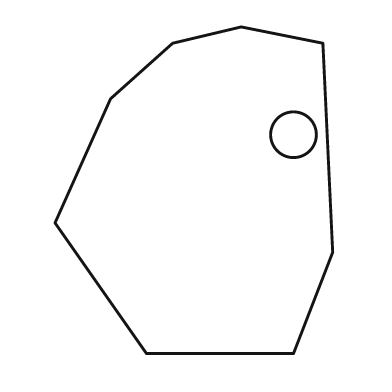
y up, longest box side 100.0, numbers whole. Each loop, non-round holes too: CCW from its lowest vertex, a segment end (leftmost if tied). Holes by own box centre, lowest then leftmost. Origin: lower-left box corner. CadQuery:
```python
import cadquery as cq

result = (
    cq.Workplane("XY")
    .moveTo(28.0, 0.0)
    .lineTo(73.0, 0.0)
    .lineTo(85.0, 31.0)
    .lineTo(82.0, 95.0)
    .lineTo(57.0, 100.0)
    .lineTo(36.0, 95.0)
    .lineTo(17.0, 78.0)
    .lineTo(0.0, 40.0)
    .close()
    .moveTo(73.0, 67.0)
    .circle(7.0)
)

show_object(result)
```